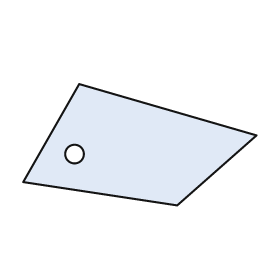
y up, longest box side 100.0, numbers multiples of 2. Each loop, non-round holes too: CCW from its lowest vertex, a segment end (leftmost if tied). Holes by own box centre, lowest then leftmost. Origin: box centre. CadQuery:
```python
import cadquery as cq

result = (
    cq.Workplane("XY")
    .moveTo(16.0, -26.0)
    .lineTo(50.0, 4.0)
    .lineTo(-26.0, 26.0)
    .lineTo(-50.0, -16.0)
    .close()
    .moveTo(-28.0, -4.0)
    .circle(4.0)
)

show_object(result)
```